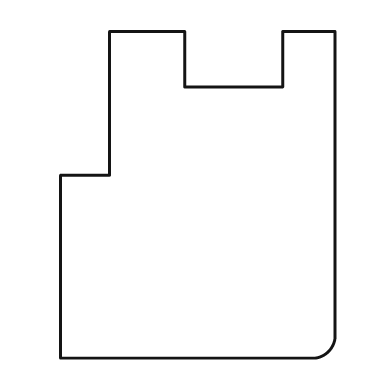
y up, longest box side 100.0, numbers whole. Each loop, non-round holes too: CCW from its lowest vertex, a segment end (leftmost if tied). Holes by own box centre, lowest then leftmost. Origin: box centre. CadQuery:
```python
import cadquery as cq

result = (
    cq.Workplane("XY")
    .moveTo(-42.0, -50.0)
    .lineTo(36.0, -50.0)
    .threePointArc((40.0, -48.0), (42.0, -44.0))
    .lineTo(42.0, 50.0)
    .lineTo(26.0, 50.0)
    .lineTo(26.0, 33.0)
    .lineTo(-4.0, 33.0)
    .lineTo(-4.0, 50.0)
    .lineTo(-27.0, 50.0)
    .lineTo(-27.0, 6.0)
    .lineTo(-42.0, 6.0)
    .close()
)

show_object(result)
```